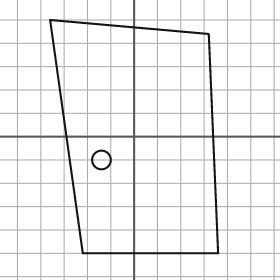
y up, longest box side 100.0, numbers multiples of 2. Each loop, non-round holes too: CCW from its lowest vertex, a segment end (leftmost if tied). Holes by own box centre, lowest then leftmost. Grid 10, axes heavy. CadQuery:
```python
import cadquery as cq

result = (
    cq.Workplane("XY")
    .moveTo(-22.0, -50.0)
    .lineTo(36.0, -50.0)
    .lineTo(32.0, 44.0)
    .lineTo(-36.0, 50.0)
    .close()
    .moveTo(-14.0, -10.0)
    .circle(4.0)
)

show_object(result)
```